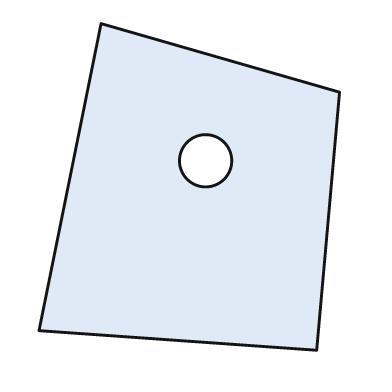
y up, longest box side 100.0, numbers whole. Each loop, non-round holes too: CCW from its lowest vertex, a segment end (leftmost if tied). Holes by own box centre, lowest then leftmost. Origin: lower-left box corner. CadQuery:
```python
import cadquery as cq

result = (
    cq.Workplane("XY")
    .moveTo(85.0, 0.0)
    .lineTo(92.0, 79.0)
    .lineTo(19.0, 100.0)
    .lineTo(0.0, 6.0)
    .close()
    .moveTo(51.0, 58.0)
    .circle(8.0)
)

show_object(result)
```